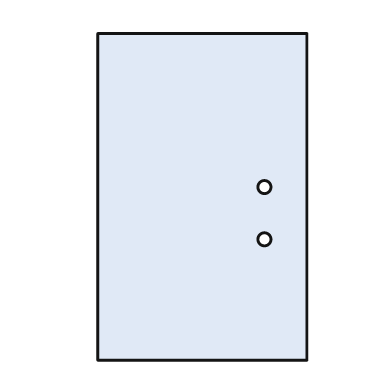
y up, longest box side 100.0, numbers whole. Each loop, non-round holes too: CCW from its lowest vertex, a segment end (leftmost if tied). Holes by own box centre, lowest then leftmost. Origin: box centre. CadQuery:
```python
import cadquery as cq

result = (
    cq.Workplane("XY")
    .moveTo(-32.0, -50.0)
    .lineTo(32.0, -50.0)
    .lineTo(32.0, 50.0)
    .lineTo(-32.0, 50.0)
    .close()
    .moveTo(19.0, -13.0)
    .circle(2.0)
    .moveTo(19.0, 3.0)
    .circle(2.0)
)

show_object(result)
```